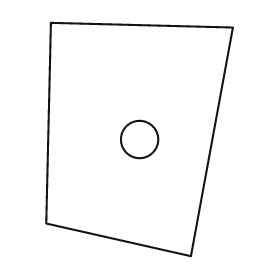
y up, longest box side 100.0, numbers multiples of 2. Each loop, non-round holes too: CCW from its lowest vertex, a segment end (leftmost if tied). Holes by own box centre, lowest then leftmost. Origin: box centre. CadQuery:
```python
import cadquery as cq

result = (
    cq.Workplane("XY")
    .moveTo(22.0, -50.0)
    .lineTo(40.0, 48.0)
    .lineTo(-38.0, 50.0)
    .lineTo(-40.0, -36.0)
    .close()
    .moveTo(0.0, 0.0)
    .circle(8.0)
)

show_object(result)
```